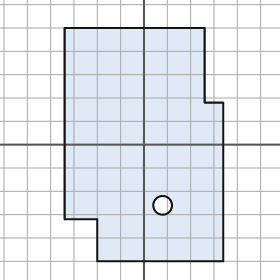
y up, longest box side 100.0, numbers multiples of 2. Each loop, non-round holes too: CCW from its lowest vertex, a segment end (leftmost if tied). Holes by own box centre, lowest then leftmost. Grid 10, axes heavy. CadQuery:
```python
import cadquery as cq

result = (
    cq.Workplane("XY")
    .moveTo(-20.0, -50.0)
    .lineTo(34.0, -50.0)
    .lineTo(34.0, 18.0)
    .lineTo(26.0, 18.0)
    .lineTo(26.0, 50.0)
    .lineTo(-34.0, 50.0)
    .lineTo(-34.0, -32.0)
    .lineTo(-20.0, -32.0)
    .close()
    .moveTo(8.0, -26.0)
    .circle(4.0)
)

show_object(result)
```